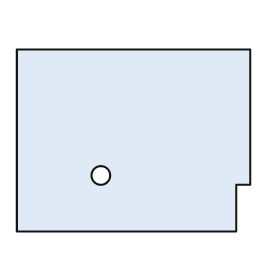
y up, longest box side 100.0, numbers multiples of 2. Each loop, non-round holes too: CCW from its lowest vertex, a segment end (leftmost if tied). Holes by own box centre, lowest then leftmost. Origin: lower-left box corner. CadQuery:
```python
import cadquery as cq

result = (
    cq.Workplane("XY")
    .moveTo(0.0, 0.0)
    .lineTo(94.0, 0.0)
    .lineTo(94.0, 20.0)
    .lineTo(100.0, 20.0)
    .lineTo(100.0, 78.0)
    .lineTo(0.0, 78.0)
    .close()
    .moveTo(36.0, 24.0)
    .circle(4.0)
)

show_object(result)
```